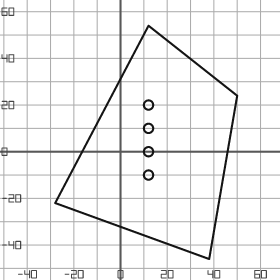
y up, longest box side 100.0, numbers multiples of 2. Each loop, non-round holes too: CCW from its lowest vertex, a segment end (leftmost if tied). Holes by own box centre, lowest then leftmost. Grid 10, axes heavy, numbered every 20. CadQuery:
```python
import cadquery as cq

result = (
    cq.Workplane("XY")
    .moveTo(38.0, -46.0)
    .lineTo(50.0, 24.0)
    .lineTo(12.0, 54.0)
    .lineTo(-28.0, -22.0)
    .close()
    .moveTo(12.0, -10.0)
    .circle(2.0)
    .moveTo(12.0, 0.0)
    .circle(2.0)
    .moveTo(12.0, 10.0)
    .circle(2.0)
    .moveTo(12.0, 20.0)
    .circle(2.0)
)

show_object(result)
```